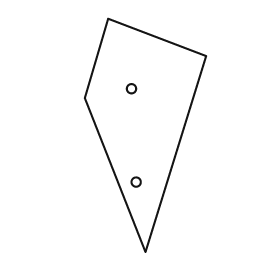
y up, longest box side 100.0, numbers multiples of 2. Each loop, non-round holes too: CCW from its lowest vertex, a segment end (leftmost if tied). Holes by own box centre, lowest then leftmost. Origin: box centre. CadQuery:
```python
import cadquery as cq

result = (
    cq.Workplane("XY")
    .moveTo(0.0, -50.0)
    .lineTo(26.0, 34.0)
    .lineTo(-16.0, 50.0)
    .lineTo(-26.0, 16.0)
    .close()
    .moveTo(-4.0, -20.0)
    .circle(2.0)
    .moveTo(-6.0, 20.0)
    .circle(2.0)
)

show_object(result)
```